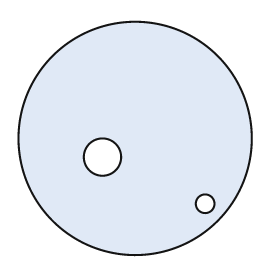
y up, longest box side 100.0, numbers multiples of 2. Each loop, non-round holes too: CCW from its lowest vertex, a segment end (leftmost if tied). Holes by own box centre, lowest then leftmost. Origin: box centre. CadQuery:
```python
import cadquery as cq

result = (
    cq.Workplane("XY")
    .moveTo(0.0, 0.0)
    .circle(50.0)
    .moveTo(30.0, -28.0)
    .circle(4.0)
    .moveTo(-14.0, -8.0)
    .circle(8.0)
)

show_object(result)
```